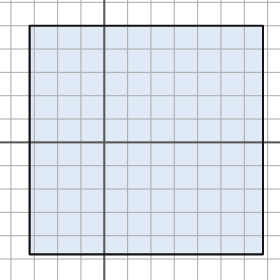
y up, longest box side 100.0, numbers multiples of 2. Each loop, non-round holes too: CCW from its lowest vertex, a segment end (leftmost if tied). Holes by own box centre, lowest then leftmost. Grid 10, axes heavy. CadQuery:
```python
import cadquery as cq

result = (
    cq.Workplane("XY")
    .moveTo(-32.0, -48.0)
    .lineTo(68.0, -48.0)
    .lineTo(68.0, 50.0)
    .lineTo(-32.0, 50.0)
    .close()
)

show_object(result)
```